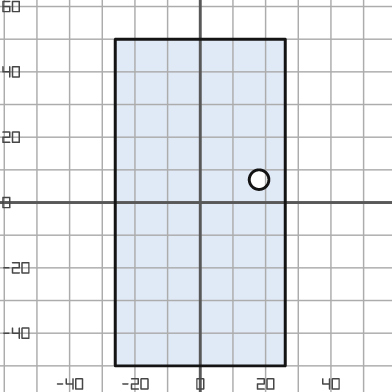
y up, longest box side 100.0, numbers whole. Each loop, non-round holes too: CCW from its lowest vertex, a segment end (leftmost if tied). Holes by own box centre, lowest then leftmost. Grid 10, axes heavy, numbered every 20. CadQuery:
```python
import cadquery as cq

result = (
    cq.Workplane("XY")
    .moveTo(-26.0, -50.0)
    .lineTo(26.0, -50.0)
    .lineTo(26.0, 50.0)
    .lineTo(-26.0, 50.0)
    .close()
    .moveTo(18.0, 7.0)
    .circle(3.0)
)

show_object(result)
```